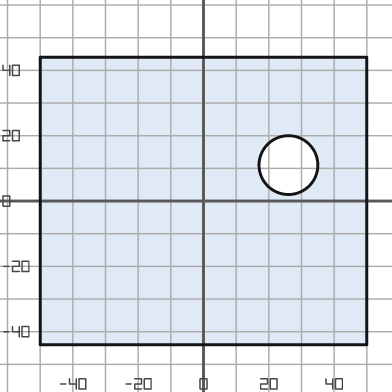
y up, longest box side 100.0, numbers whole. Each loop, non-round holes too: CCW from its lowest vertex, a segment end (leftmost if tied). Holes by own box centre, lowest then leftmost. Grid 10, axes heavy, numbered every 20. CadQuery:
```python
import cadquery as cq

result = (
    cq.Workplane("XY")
    .moveTo(-50.0, -44.0)
    .lineTo(50.0, -44.0)
    .lineTo(50.0, 44.0)
    .lineTo(-50.0, 44.0)
    .close()
    .moveTo(26.0, 11.0)
    .circle(9.0)
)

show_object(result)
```